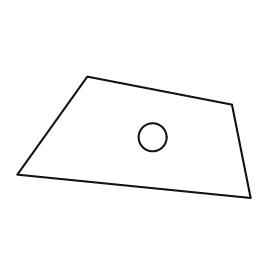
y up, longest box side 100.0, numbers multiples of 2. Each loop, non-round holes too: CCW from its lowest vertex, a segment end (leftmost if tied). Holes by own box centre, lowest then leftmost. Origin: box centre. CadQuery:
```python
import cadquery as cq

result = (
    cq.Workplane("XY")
    .moveTo(50.0, -26.0)
    .lineTo(42.0, 14.0)
    .lineTo(-20.0, 26.0)
    .lineTo(-50.0, -16.0)
    .close()
    .moveTo(8.0, 0.0)
    .circle(6.0)
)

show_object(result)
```